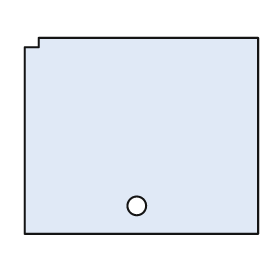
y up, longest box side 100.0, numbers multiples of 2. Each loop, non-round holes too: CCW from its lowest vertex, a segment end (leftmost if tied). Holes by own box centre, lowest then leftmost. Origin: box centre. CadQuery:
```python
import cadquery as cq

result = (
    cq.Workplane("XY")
    .moveTo(-50.0, -42.0)
    .lineTo(50.0, -42.0)
    .lineTo(50.0, 42.0)
    .lineTo(-44.0, 42.0)
    .lineTo(-44.0, 38.0)
    .lineTo(-50.0, 38.0)
    .close()
    .moveTo(-2.0, -30.0)
    .circle(4.0)
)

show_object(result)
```